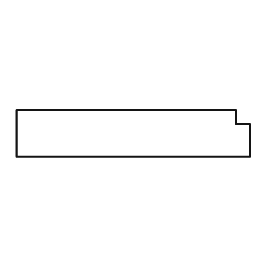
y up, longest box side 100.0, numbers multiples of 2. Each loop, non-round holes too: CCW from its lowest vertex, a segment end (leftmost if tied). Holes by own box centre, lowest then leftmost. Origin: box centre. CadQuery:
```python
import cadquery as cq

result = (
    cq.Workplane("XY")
    .moveTo(-50.0, -10.0)
    .lineTo(50.0, -10.0)
    .lineTo(50.0, 4.0)
    .lineTo(44.0, 4.0)
    .lineTo(44.0, 10.0)
    .lineTo(-50.0, 10.0)
    .close()
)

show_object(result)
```